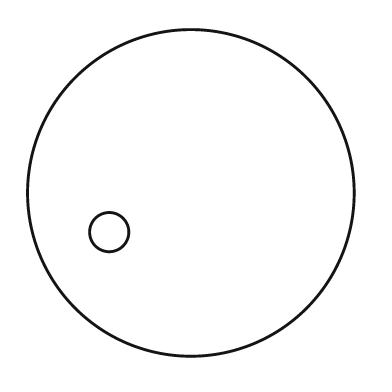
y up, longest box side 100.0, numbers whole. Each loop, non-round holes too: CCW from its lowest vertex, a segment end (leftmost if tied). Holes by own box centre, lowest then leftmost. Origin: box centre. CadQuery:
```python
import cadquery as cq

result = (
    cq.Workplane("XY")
    .moveTo(0.0, 0.0)
    .circle(50.0)
    .moveTo(-25.0, -12.0)
    .circle(6.0)
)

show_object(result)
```